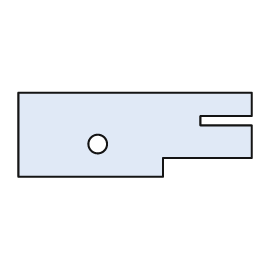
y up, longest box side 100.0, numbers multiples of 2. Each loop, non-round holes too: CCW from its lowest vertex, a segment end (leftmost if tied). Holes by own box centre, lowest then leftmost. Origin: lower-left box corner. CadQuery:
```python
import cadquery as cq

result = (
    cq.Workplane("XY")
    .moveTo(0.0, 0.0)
    .lineTo(62.0, 0.0)
    .lineTo(62.0, 8.0)
    .lineTo(100.0, 8.0)
    .lineTo(100.0, 22.0)
    .lineTo(78.0, 22.0)
    .lineTo(78.0, 26.0)
    .lineTo(100.0, 26.0)
    .lineTo(100.0, 36.0)
    .lineTo(0.0, 36.0)
    .close()
    .moveTo(34.0, 14.0)
    .circle(4.0)
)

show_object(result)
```